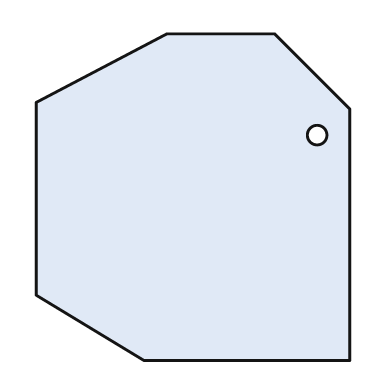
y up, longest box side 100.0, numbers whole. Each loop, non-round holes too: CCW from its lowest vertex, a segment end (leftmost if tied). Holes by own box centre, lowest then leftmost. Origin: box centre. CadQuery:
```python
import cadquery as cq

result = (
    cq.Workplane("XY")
    .moveTo(-15.0, -50.0)
    .lineTo(48.0, -50.0)
    .lineTo(48.0, 27.0)
    .lineTo(25.0, 50.0)
    .lineTo(-8.0, 50.0)
    .lineTo(-48.0, 29.0)
    .lineTo(-48.0, -30.0)
    .close()
    .moveTo(38.0, 19.0)
    .circle(3.0)
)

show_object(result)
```